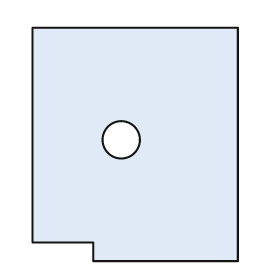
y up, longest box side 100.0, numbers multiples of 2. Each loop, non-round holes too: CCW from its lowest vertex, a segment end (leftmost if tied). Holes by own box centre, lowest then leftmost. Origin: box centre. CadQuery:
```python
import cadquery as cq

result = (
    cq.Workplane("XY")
    .moveTo(-18.0, -50.0)
    .lineTo(44.0, -50.0)
    .lineTo(44.0, 50.0)
    .lineTo(-44.0, 50.0)
    .lineTo(-44.0, -42.0)
    .lineTo(-18.0, -42.0)
    .close()
    .moveTo(-6.0, 2.0)
    .circle(8.0)
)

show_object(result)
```